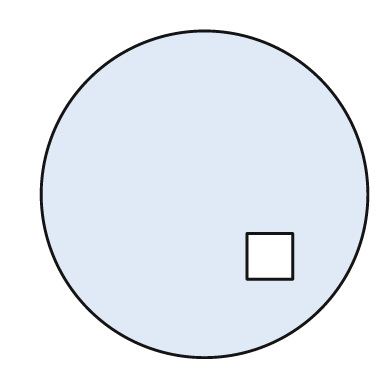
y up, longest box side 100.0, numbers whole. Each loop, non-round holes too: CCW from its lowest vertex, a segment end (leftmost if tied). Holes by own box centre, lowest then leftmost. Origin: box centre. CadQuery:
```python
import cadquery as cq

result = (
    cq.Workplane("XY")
    .moveTo(0.0, 0.0)
    .circle(50.0)
    .moveTo(13.0, -26.0)
    .lineTo(27.0, -26.0)
    .lineTo(27.0, -12.0)
    .lineTo(13.0, -12.0)
    .close()
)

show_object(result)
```